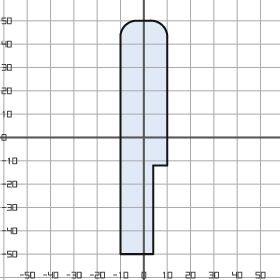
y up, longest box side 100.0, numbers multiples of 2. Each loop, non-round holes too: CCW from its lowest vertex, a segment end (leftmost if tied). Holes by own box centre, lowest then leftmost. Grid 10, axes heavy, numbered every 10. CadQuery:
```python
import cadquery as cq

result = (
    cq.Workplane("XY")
    .moveTo(-10.0, -50.0)
    .lineTo(4.0, -50.0)
    .lineTo(4.0, -12.0)
    .lineTo(10.0, -12.0)
    .lineTo(10.0, 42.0)
    .threePointArc((8.0, 48.0), (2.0, 50.0))
    .lineTo(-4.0, 50.0)
    .threePointArc((-8.0, 48.0), (-10.0, 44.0))
    .close()
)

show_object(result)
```